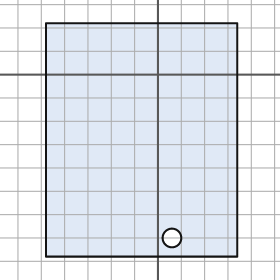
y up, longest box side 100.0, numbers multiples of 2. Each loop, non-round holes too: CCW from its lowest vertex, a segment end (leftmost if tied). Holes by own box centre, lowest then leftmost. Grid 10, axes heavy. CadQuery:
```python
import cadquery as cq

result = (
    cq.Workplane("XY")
    .moveTo(-48.0, -78.0)
    .lineTo(34.0, -78.0)
    .lineTo(34.0, 22.0)
    .lineTo(-48.0, 22.0)
    .close()
    .moveTo(6.0, -70.0)
    .circle(4.0)
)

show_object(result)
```